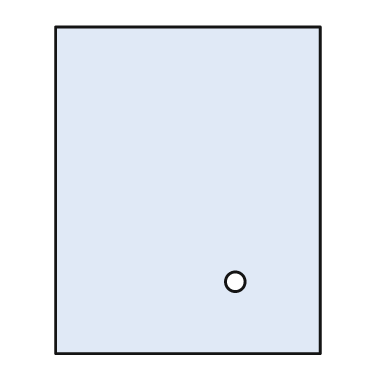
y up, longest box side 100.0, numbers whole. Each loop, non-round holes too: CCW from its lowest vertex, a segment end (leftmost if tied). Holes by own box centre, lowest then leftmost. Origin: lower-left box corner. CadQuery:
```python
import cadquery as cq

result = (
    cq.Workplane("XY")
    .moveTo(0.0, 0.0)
    .lineTo(81.0, 0.0)
    .lineTo(81.0, 100.0)
    .lineTo(0.0, 100.0)
    .close()
    .moveTo(55.0, 22.0)
    .circle(3.0)
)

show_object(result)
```